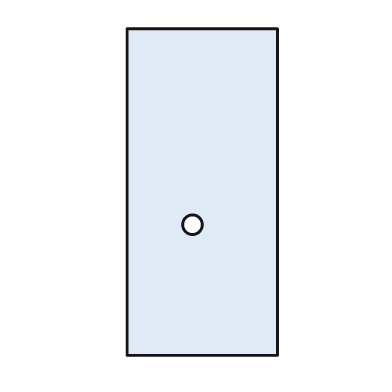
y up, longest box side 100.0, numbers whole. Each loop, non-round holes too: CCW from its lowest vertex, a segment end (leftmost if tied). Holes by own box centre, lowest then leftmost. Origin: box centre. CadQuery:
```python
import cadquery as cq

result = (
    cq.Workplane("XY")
    .moveTo(-23.0, -50.0)
    .lineTo(23.0, -50.0)
    .lineTo(23.0, 50.0)
    .lineTo(-23.0, 50.0)
    .close()
    .moveTo(-3.0, -10.0)
    .circle(3.0)
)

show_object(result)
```